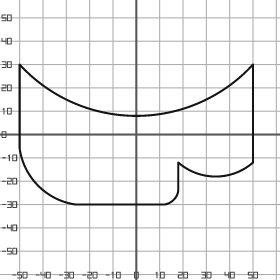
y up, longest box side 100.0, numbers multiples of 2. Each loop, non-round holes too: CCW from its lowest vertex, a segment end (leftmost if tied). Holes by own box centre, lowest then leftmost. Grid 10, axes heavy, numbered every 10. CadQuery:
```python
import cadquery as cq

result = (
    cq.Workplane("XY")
    .moveTo(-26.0, -30.0)
    .lineTo(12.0, -30.0)
    .threePointArc((16.0, -28.0), (18.0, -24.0))
    .lineTo(18.0, -12.0)
    .threePointArc((34.0, -18.0), (50.0, -12.0))
    .lineTo(50.0, 30.0)
    .threePointArc((0.0, 8.0), (-50.0, 30.0))
    .lineTo(-50.0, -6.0)
    .threePointArc((-42.0, -22.0), (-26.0, -30.0))
    .close()
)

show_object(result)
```